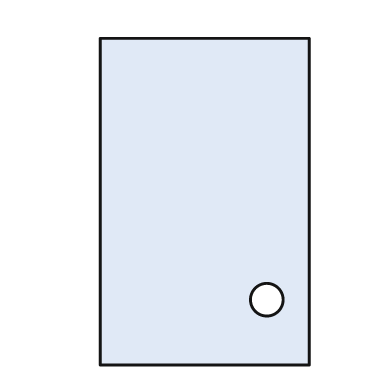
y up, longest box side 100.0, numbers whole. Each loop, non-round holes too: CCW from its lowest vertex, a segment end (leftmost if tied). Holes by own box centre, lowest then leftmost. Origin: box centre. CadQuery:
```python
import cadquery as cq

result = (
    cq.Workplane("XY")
    .moveTo(-32.0, -50.0)
    .lineTo(32.0, -50.0)
    .lineTo(32.0, 50.0)
    .lineTo(-32.0, 50.0)
    .close()
    .moveTo(19.0, -30.0)
    .circle(5.0)
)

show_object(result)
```